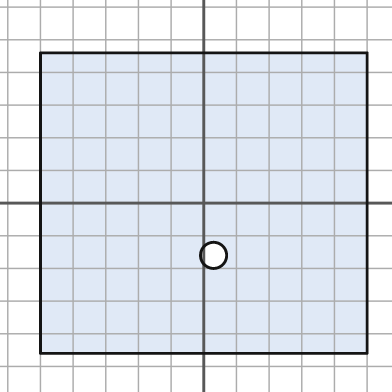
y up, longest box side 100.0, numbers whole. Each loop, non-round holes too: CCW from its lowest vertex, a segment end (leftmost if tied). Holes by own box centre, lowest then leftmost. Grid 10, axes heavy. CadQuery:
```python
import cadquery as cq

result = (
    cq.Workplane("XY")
    .moveTo(-50.0, -46.0)
    .lineTo(50.0, -46.0)
    .lineTo(50.0, 46.0)
    .lineTo(-50.0, 46.0)
    .close()
    .moveTo(3.0, -16.0)
    .circle(4.0)
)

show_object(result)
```